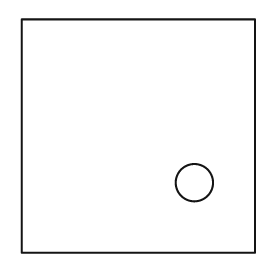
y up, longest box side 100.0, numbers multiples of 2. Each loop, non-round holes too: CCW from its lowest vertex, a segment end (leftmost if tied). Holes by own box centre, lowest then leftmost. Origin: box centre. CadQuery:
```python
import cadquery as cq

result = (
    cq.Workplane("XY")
    .moveTo(-50.0, -50.0)
    .lineTo(50.0, -50.0)
    .lineTo(50.0, 50.0)
    .lineTo(-50.0, 50.0)
    .close()
    .moveTo(24.0, -20.0)
    .circle(8.0)
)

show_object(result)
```